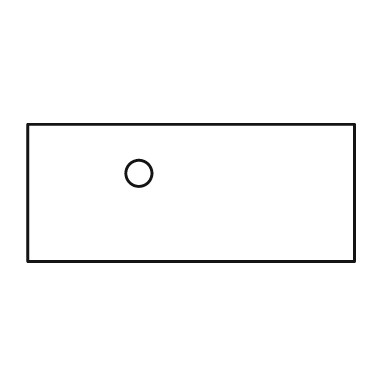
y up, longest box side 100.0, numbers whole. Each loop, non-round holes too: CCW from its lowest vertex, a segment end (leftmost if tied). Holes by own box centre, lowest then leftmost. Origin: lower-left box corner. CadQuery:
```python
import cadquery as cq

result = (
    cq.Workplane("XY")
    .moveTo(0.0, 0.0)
    .lineTo(100.0, 0.0)
    .lineTo(100.0, 42.0)
    .lineTo(0.0, 42.0)
    .close()
    .moveTo(34.0, 27.0)
    .circle(4.0)
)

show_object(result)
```